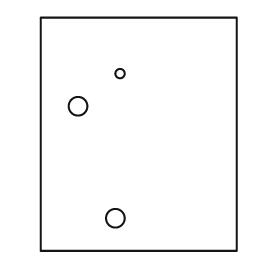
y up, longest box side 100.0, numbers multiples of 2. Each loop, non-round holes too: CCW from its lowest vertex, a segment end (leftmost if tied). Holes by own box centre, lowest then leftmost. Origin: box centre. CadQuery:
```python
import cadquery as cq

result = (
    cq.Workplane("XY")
    .moveTo(-42.0, -50.0)
    .lineTo(42.0, -50.0)
    .lineTo(42.0, 50.0)
    .lineTo(-42.0, 50.0)
    .close()
    .moveTo(-10.0, -36.0)
    .circle(4.0)
    .moveTo(-26.0, 12.0)
    .circle(4.0)
    .moveTo(-8.0, 26.0)
    .circle(2.0)
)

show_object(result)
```